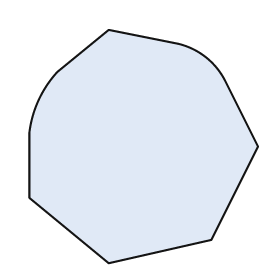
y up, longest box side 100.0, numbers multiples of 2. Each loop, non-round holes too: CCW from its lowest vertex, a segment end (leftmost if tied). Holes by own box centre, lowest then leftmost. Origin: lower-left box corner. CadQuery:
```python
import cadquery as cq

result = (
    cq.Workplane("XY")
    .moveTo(34.0, 0.0)
    .lineTo(78.0, 10.0)
    .lineTo(98.0, 50.0)
    .lineTo(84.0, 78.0)
    .threePointArc((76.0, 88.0), (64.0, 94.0))
    .lineTo(34.0, 100.0)
    .lineTo(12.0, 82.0)
    .threePointArc((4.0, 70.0), (0.0, 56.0))
    .lineTo(0.0, 28.0)
    .close()
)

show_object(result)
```